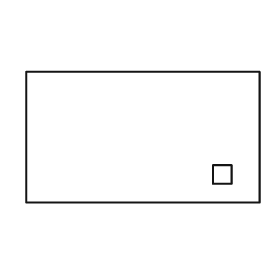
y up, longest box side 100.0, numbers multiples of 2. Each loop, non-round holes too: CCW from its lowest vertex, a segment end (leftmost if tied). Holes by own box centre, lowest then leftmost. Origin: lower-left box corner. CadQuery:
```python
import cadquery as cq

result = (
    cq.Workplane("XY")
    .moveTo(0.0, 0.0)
    .lineTo(100.0, 0.0)
    .lineTo(100.0, 56.0)
    .lineTo(0.0, 56.0)
    .close()
    .moveTo(80.0, 8.0)
    .lineTo(88.0, 8.0)
    .lineTo(88.0, 16.0)
    .lineTo(80.0, 16.0)
    .close()
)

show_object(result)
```